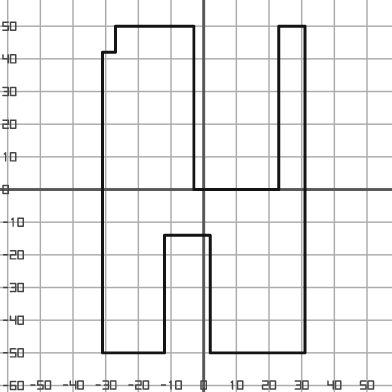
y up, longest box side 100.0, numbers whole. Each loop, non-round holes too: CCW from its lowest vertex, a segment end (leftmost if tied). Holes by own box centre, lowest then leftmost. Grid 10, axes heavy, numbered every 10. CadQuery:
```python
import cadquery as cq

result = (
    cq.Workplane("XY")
    .moveTo(-31.0, -50.0)
    .lineTo(-12.0, -50.0)
    .lineTo(-12.0, -14.0)
    .lineTo(2.0, -14.0)
    .lineTo(2.0, -50.0)
    .lineTo(31.0, -50.0)
    .lineTo(31.0, 50.0)
    .lineTo(23.0, 50.0)
    .lineTo(23.0, 0.0)
    .lineTo(-3.0, 0.0)
    .lineTo(-3.0, 50.0)
    .lineTo(-27.0, 50.0)
    .lineTo(-27.0, 42.0)
    .lineTo(-31.0, 42.0)
    .close()
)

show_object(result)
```